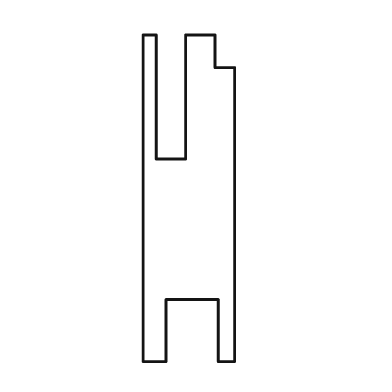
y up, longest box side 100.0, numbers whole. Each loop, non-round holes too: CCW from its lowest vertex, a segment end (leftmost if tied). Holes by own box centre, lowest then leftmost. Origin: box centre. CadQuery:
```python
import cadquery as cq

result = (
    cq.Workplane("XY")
    .moveTo(-14.0, -50.0)
    .lineTo(-7.0, -50.0)
    .lineTo(-7.0, -31.0)
    .lineTo(9.0, -31.0)
    .lineTo(9.0, -50.0)
    .lineTo(14.0, -50.0)
    .lineTo(14.0, 40.0)
    .lineTo(8.0, 40.0)
    .lineTo(8.0, 50.0)
    .lineTo(-1.0, 50.0)
    .lineTo(-1.0, 12.0)
    .lineTo(-10.0, 12.0)
    .lineTo(-10.0, 50.0)
    .lineTo(-14.0, 50.0)
    .close()
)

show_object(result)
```